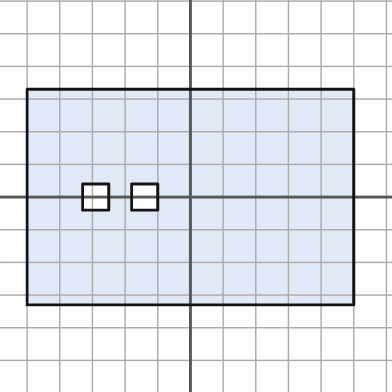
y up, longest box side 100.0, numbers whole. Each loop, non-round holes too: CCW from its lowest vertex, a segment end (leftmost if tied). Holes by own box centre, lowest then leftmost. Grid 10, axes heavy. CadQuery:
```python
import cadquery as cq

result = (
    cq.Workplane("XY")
    .moveTo(-50.0, -33.0)
    .lineTo(50.0, -33.0)
    .lineTo(50.0, 33.0)
    .lineTo(-50.0, 33.0)
    .close()
    .moveTo(-33.0, -4.0)
    .lineTo(-25.0, -4.0)
    .lineTo(-25.0, 4.0)
    .lineTo(-33.0, 4.0)
    .close()
    .moveTo(-18.0, -4.0)
    .lineTo(-10.0, -4.0)
    .lineTo(-10.0, 4.0)
    .lineTo(-18.0, 4.0)
    .close()
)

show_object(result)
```